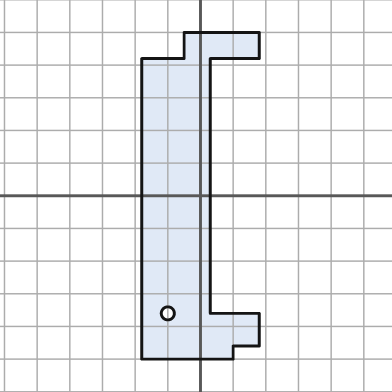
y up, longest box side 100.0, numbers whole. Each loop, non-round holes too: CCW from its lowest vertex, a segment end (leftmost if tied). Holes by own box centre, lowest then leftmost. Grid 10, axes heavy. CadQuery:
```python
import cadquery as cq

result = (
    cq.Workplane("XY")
    .moveTo(-18.0, -50.0)
    .lineTo(10.0, -50.0)
    .lineTo(10.0, -46.0)
    .lineTo(18.0, -46.0)
    .lineTo(18.0, -36.0)
    .lineTo(3.0, -36.0)
    .lineTo(3.0, 42.0)
    .lineTo(18.0, 42.0)
    .lineTo(18.0, 50.0)
    .lineTo(-5.0, 50.0)
    .lineTo(-5.0, 42.0)
    .lineTo(-18.0, 42.0)
    .close()
    .moveTo(-10.0, -36.0)
    .circle(2.0)
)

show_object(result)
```